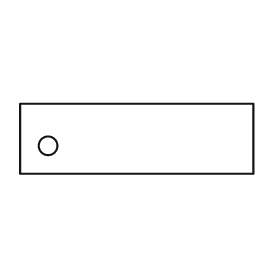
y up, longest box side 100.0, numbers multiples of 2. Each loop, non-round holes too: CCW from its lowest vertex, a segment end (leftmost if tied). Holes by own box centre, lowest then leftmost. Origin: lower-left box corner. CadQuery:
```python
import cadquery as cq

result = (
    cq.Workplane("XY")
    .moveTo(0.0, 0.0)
    .lineTo(100.0, 0.0)
    .lineTo(100.0, 30.0)
    .lineTo(0.0, 30.0)
    .close()
    .moveTo(12.0, 12.0)
    .circle(4.0)
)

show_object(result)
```